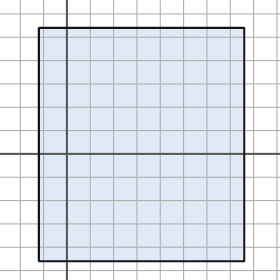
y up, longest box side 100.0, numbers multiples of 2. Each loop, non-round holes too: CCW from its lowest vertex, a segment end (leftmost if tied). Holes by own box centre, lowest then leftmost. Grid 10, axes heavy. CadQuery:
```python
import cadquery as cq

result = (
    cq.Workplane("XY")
    .moveTo(-12.0, -46.0)
    .lineTo(76.0, -46.0)
    .lineTo(76.0, 54.0)
    .lineTo(-12.0, 54.0)
    .close()
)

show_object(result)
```